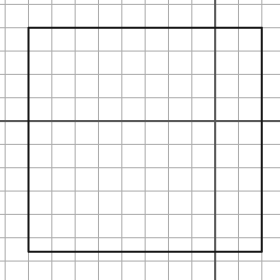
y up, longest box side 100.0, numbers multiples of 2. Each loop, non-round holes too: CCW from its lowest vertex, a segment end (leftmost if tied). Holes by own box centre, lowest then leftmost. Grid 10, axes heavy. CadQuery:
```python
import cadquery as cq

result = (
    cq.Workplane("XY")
    .moveTo(-80.0, -56.0)
    .lineTo(20.0, -56.0)
    .lineTo(20.0, 40.0)
    .lineTo(-80.0, 40.0)
    .close()
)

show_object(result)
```